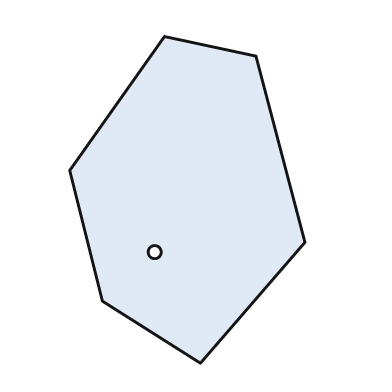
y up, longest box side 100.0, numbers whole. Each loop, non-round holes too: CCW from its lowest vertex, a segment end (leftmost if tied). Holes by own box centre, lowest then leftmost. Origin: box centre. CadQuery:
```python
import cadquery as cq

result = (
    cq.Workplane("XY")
    .moveTo(4.0, -50.0)
    .lineTo(36.0, -13.0)
    .lineTo(21.0, 44.0)
    .lineTo(-7.0, 50.0)
    .lineTo(-36.0, 9.0)
    .lineTo(-26.0, -31.0)
    .close()
    .moveTo(-10.0, -16.0)
    .circle(2.0)
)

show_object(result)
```